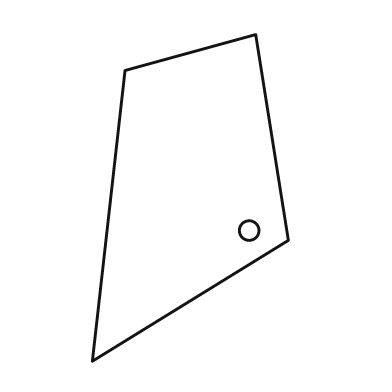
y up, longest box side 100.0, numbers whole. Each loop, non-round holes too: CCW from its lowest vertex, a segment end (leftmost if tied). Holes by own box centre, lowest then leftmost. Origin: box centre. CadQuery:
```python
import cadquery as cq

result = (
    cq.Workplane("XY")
    .moveTo(-30.0, -50.0)
    .lineTo(30.0, -13.0)
    .lineTo(20.0, 50.0)
    .lineTo(-20.0, 39.0)
    .close()
    .moveTo(18.0, -10.0)
    .circle(3.0)
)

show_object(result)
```